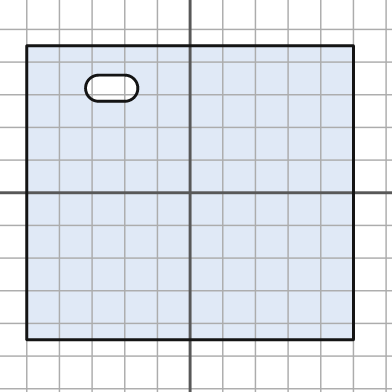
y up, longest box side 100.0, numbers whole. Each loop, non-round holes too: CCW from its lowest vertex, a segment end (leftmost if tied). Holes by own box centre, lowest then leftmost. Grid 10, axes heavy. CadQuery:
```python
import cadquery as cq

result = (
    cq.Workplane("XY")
    .moveTo(-50.0, -45.0)
    .lineTo(50.0, -45.0)
    .lineTo(50.0, 45.0)
    .lineTo(-50.0, 45.0)
    .close()
    .moveTo(-28.0, 28.0)
    .lineTo(-20.0, 28.0)
    .threePointArc((-16.0, 32.0), (-20.0, 36.0))
    .lineTo(-28.0, 36.0)
    .threePointArc((-32.0, 32.0), (-28.0, 28.0))
    .close()
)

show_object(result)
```